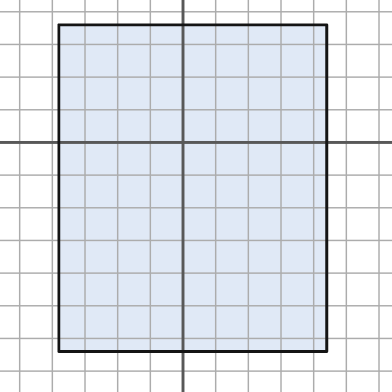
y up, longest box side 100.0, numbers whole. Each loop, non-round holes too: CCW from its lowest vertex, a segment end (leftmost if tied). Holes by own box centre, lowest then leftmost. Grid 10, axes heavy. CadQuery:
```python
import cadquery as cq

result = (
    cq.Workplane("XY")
    .moveTo(-38.0, -64.0)
    .lineTo(44.0, -64.0)
    .lineTo(44.0, 36.0)
    .lineTo(-38.0, 36.0)
    .close()
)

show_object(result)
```